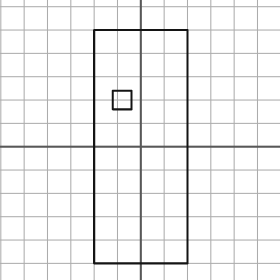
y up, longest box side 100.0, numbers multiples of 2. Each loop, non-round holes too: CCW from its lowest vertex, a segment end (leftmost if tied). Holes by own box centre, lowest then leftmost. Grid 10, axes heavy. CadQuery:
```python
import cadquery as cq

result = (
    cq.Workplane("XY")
    .moveTo(-20.0, -50.0)
    .lineTo(20.0, -50.0)
    .lineTo(20.0, 50.0)
    .lineTo(-20.0, 50.0)
    .close()
    .moveTo(-12.0, 16.0)
    .lineTo(-4.0, 16.0)
    .lineTo(-4.0, 24.0)
    .lineTo(-12.0, 24.0)
    .close()
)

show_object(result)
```